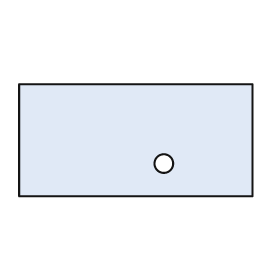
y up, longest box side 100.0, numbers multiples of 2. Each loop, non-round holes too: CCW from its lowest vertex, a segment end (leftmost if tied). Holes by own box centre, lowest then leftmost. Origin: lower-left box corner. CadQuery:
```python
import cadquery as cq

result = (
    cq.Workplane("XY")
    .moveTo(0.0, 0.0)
    .lineTo(100.0, 0.0)
    .lineTo(100.0, 48.0)
    .lineTo(0.0, 48.0)
    .close()
    .moveTo(62.0, 14.0)
    .circle(4.0)
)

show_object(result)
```